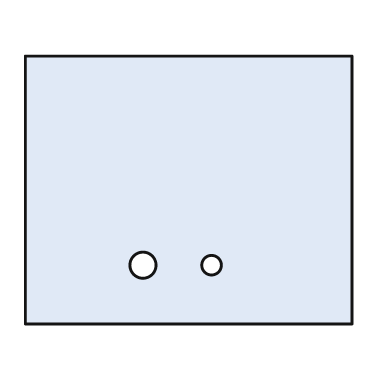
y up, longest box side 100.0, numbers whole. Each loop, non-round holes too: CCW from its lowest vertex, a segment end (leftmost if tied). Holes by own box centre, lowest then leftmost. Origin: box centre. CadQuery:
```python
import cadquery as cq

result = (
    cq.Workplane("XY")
    .moveTo(-50.0, -41.0)
    .lineTo(50.0, -41.0)
    .lineTo(50.0, 41.0)
    .lineTo(-50.0, 41.0)
    .close()
    .moveTo(-14.0, -23.0)
    .circle(4.0)
    .moveTo(7.0, -23.0)
    .circle(3.0)
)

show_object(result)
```